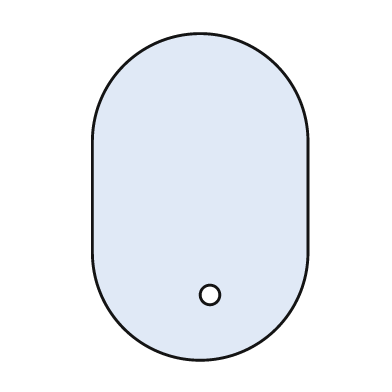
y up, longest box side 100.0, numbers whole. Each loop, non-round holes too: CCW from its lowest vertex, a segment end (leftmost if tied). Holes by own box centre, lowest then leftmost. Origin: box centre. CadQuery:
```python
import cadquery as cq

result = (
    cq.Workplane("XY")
    .moveTo(-33.0, -17.0)
    .threePointArc((0.0, -50.0), (33.0, -17.0))
    .lineTo(33.0, 17.0)
    .threePointArc((0.0, 50.0), (-33.0, 17.0))
    .close()
    .moveTo(3.0, -30.0)
    .circle(3.0)
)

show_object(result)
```